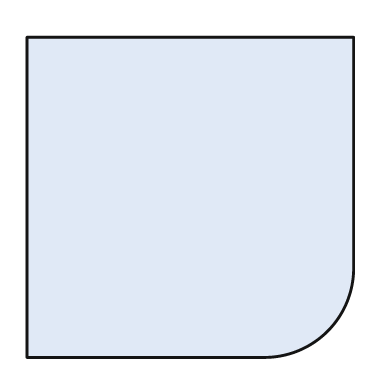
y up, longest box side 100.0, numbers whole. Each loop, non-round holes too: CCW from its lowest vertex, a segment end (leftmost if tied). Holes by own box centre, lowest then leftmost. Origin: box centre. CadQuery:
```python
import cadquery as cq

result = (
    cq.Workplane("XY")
    .moveTo(-50.0, -49.0)
    .lineTo(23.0, -49.0)
    .threePointArc((42.0, -41.0), (50.0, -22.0))
    .lineTo(50.0, 49.0)
    .lineTo(-50.0, 49.0)
    .close()
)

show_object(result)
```